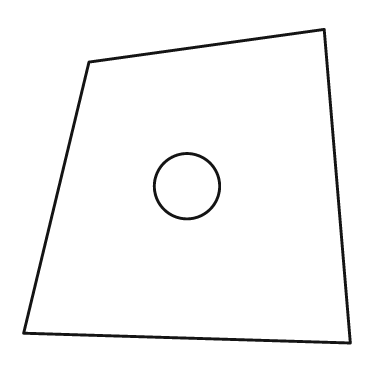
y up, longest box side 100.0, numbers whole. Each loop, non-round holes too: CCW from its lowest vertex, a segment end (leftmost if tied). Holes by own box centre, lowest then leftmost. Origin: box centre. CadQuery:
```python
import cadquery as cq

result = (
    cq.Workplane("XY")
    .moveTo(50.0, -48.0)
    .lineTo(42.0, 48.0)
    .lineTo(-30.0, 38.0)
    .lineTo(-50.0, -45.0)
    .close()
    .moveTo(0.0, 0.0)
    .circle(10.0)
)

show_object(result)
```